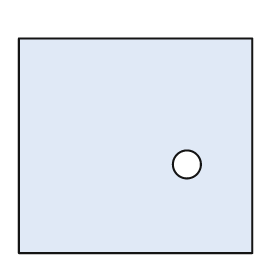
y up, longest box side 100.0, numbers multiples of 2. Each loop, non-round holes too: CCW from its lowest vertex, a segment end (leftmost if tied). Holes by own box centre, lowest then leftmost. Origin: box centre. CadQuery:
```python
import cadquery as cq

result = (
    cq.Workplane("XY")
    .moveTo(-50.0, -46.0)
    .lineTo(50.0, -46.0)
    .lineTo(50.0, 46.0)
    .lineTo(-50.0, 46.0)
    .close()
    .moveTo(22.0, -8.0)
    .circle(6.0)
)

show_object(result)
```